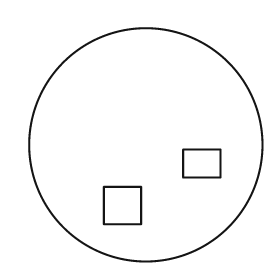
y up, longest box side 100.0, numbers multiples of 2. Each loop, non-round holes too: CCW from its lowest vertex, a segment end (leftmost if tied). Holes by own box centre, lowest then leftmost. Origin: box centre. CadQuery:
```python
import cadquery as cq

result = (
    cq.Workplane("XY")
    .moveTo(0.0, 0.0)
    .circle(50.0)
    .moveTo(-18.0, -34.0)
    .lineTo(-2.0, -34.0)
    .lineTo(-2.0, -18.0)
    .lineTo(-18.0, -18.0)
    .close()
    .moveTo(16.0, -14.0)
    .lineTo(32.0, -14.0)
    .lineTo(32.0, -2.0)
    .lineTo(16.0, -2.0)
    .close()
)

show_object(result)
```